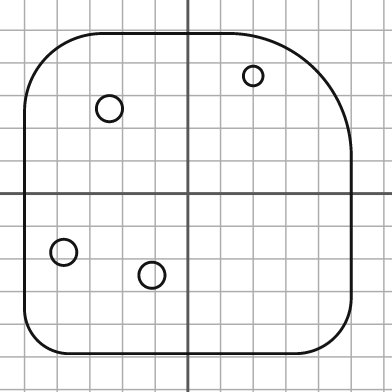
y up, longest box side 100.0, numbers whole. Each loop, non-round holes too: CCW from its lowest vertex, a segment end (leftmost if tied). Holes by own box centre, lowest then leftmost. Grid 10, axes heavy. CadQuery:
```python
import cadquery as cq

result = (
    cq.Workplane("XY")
    .moveTo(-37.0, -49.0)
    .lineTo(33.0, -49.0)
    .threePointArc((45.0, -44.0), (50.0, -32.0))
    .lineTo(50.0, 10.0)
    .threePointArc((39.0, 38.0), (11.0, 49.0))
    .lineTo(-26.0, 49.0)
    .threePointArc((-43.0, 42.0), (-50.0, 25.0))
    .lineTo(-50.0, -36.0)
    .threePointArc((-46.0, -45.0), (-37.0, -49.0))
    .close()
    .moveTo(-11.0, -25.0)
    .circle(4.0)
    .moveTo(-38.0, -18.0)
    .circle(4.0)
    .moveTo(-24.0, 26.0)
    .circle(4.0)
    .moveTo(20.0, 36.0)
    .circle(3.0)
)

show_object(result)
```